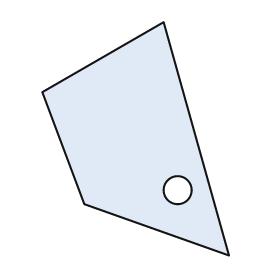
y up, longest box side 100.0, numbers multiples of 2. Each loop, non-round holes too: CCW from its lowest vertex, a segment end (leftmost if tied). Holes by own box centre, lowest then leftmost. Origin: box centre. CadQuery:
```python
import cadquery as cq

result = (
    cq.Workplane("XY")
    .moveTo(40.0, -50.0)
    .lineTo(12.0, 50.0)
    .lineTo(-40.0, 20.0)
    .lineTo(-22.0, -28.0)
    .close()
    .moveTo(18.0, -22.0)
    .circle(6.0)
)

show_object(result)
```